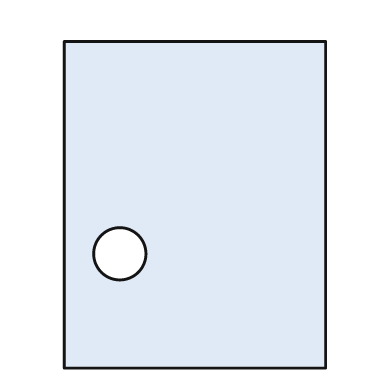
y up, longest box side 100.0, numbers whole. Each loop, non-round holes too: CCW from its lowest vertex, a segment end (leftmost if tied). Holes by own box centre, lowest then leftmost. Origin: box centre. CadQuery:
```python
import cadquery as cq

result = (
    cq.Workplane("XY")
    .moveTo(-40.0, -50.0)
    .lineTo(40.0, -50.0)
    .lineTo(40.0, 50.0)
    .lineTo(-40.0, 50.0)
    .close()
    .moveTo(-23.0, -15.0)
    .circle(8.0)
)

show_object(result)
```